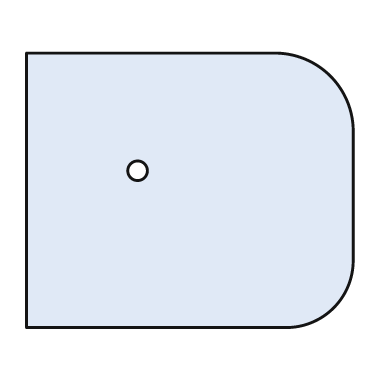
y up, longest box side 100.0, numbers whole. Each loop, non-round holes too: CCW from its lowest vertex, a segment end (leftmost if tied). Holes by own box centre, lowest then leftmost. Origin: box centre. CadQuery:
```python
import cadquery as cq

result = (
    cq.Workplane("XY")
    .moveTo(-50.0, -42.0)
    .lineTo(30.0, -42.0)
    .threePointArc((44.0, -36.0), (50.0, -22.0))
    .lineTo(50.0, 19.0)
    .threePointArc((43.0, 35.0), (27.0, 42.0))
    .lineTo(-50.0, 42.0)
    .close()
    .moveTo(-16.0, 6.0)
    .circle(3.0)
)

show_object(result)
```